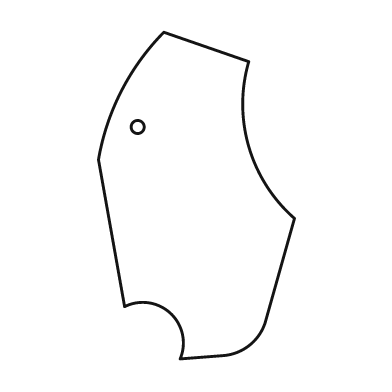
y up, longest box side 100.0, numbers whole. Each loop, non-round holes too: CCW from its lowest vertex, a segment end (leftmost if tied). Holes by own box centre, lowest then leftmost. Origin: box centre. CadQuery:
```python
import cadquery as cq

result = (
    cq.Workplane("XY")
    .moveTo(-5.0, -50.0)
    .lineTo(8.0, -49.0)
    .threePointArc((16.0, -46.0), (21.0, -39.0))
    .lineTo(30.0, -7.0)
    .threePointArc((16.0, 15.0), (16.0, 41.0))
    .lineTo(-10.0, 50.0)
    .threePointArc((-23.0, 32.0), (-30.0, 11.0))
    .lineTo(-22.0, -34.0)
    .threePointArc((-8.0, -36.0), (-5.0, -50.0))
    .close()
    .moveTo(-18.0, 21.0)
    .circle(2.0)
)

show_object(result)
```